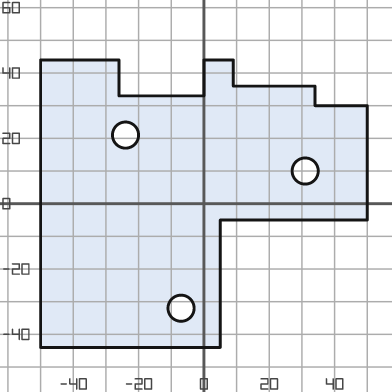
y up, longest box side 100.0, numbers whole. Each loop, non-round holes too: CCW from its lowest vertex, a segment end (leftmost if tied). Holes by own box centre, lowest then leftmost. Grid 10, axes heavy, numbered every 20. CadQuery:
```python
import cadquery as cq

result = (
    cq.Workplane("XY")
    .moveTo(-50.0, -44.0)
    .lineTo(5.0, -44.0)
    .lineTo(5.0, -5.0)
    .lineTo(50.0, -5.0)
    .lineTo(50.0, 30.0)
    .lineTo(34.0, 30.0)
    .lineTo(34.0, 36.0)
    .lineTo(9.0, 36.0)
    .lineTo(9.0, 44.0)
    .lineTo(0.0, 44.0)
    .lineTo(0.0, 33.0)
    .lineTo(-26.0, 33.0)
    .lineTo(-26.0, 44.0)
    .lineTo(-50.0, 44.0)
    .close()
    .moveTo(-7.0, -32.0)
    .circle(4.0)
    .moveTo(31.0, 10.0)
    .circle(4.0)
    .moveTo(-24.0, 21.0)
    .circle(4.0)
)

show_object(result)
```